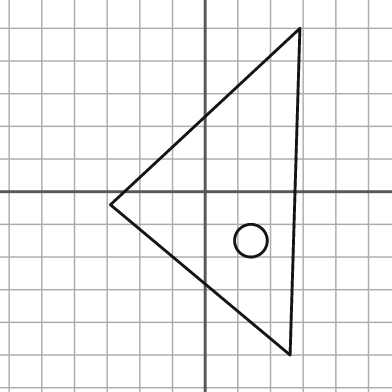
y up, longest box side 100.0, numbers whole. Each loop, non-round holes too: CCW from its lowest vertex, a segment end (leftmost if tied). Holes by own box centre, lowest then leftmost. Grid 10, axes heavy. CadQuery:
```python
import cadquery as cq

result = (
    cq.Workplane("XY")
    .moveTo(26.0, -50.0)
    .lineTo(29.0, 50.0)
    .lineTo(-29.0, -4.0)
    .close()
    .moveTo(14.0, -15.0)
    .circle(5.0)
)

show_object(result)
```